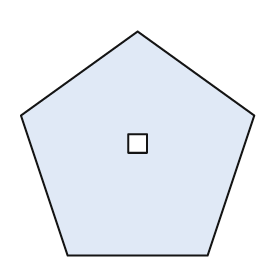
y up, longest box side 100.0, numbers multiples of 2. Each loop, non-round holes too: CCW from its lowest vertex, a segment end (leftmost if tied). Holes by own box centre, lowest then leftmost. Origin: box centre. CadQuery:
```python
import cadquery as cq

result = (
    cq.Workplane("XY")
    .moveTo(-30.0, -48.0)
    .lineTo(30.0, -48.0)
    .lineTo(50.0, 12.0)
    .lineTo(0.0, 48.0)
    .lineTo(-50.0, 12.0)
    .close()
    .moveTo(-4.0, -4.0)
    .lineTo(4.0, -4.0)
    .lineTo(4.0, 4.0)
    .lineTo(-4.0, 4.0)
    .close()
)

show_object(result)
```